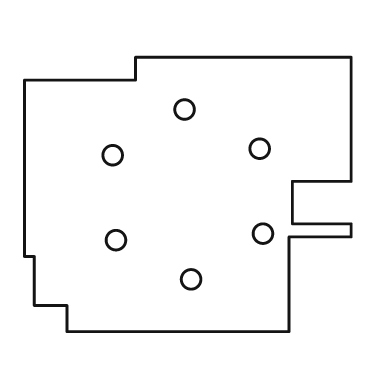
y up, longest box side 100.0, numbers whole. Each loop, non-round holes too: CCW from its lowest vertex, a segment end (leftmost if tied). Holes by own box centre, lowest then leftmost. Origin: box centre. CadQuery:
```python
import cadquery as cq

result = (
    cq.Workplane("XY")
    .moveTo(-37.0, -42.0)
    .lineTo(31.0, -42.0)
    .lineTo(31.0, -13.0)
    .lineTo(50.0, -13.0)
    .lineTo(50.0, -9.0)
    .lineTo(32.0, -9.0)
    .lineTo(32.0, 4.0)
    .lineTo(50.0, 4.0)
    .lineTo(50.0, 42.0)
    .lineTo(-16.0, 42.0)
    .lineTo(-16.0, 35.0)
    .lineTo(-50.0, 35.0)
    .lineTo(-50.0, -19.0)
    .lineTo(-47.0, -19.0)
    .lineTo(-47.0, -34.0)
    .lineTo(-37.0, -34.0)
    .close()
    .moveTo(1.0, -26.0)
    .circle(3.0)
    .moveTo(-22.0, -14.0)
    .circle(3.0)
    .moveTo(23.0, -12.0)
    .circle(3.0)
    .moveTo(-23.0, 12.0)
    .circle(3.0)
    .moveTo(22.0, 14.0)
    .circle(3.0)
    .moveTo(-1.0, 26.0)
    .circle(3.0)
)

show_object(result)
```